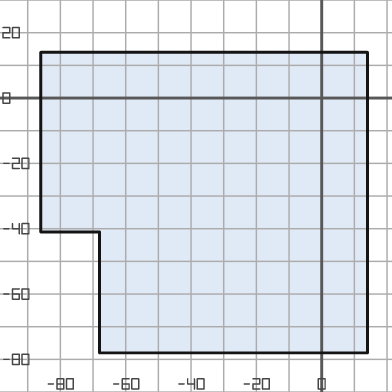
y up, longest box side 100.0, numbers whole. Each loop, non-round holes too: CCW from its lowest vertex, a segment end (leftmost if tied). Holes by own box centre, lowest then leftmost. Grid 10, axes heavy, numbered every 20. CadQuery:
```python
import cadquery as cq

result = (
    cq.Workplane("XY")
    .moveTo(-68.0, -78.0)
    .lineTo(14.0, -78.0)
    .lineTo(14.0, 14.0)
    .lineTo(-86.0, 14.0)
    .lineTo(-86.0, -41.0)
    .lineTo(-68.0, -41.0)
    .close()
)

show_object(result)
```